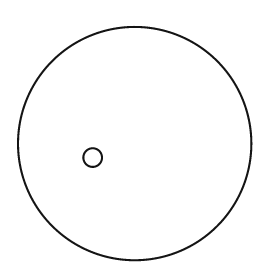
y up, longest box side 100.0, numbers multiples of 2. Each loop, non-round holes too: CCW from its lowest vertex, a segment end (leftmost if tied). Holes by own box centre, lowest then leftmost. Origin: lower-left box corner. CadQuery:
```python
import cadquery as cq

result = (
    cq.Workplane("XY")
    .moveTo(50.0, 50.0)
    .circle(50.0)
    .moveTo(32.0, 44.0)
    .circle(4.0)
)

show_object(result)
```